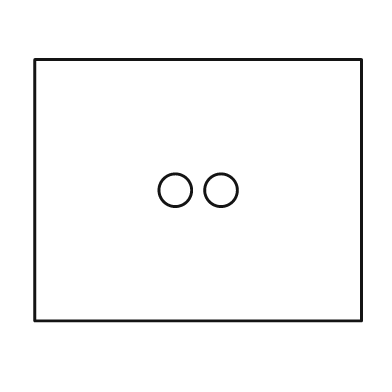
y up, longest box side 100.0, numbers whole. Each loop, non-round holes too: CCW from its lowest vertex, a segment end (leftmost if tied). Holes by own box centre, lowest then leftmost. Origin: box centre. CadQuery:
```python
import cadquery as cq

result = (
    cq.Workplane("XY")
    .moveTo(-50.0, -40.0)
    .lineTo(50.0, -40.0)
    .lineTo(50.0, 40.0)
    .lineTo(-50.0, 40.0)
    .close()
    .moveTo(-7.0, 0.0)
    .circle(5.0)
    .moveTo(7.0, 0.0)
    .circle(5.0)
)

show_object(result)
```